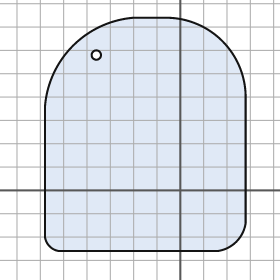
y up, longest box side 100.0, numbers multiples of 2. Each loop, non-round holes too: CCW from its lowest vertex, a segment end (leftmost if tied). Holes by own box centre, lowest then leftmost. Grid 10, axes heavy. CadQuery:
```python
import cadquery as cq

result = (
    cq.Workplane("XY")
    .moveTo(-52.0, -26.0)
    .lineTo(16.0, -26.0)
    .threePointArc((24.0, -22.0), (28.0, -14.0))
    .lineTo(28.0, 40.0)
    .threePointArc((18.0, 64.0), (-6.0, 74.0))
    .lineTo(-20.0, 74.0)
    .threePointArc((-46.0, 62.0), (-58.0, 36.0))
    .lineTo(-58.0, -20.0)
    .threePointArc((-56.0, -24.0), (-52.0, -26.0))
    .close()
    .moveTo(-36.0, 58.0)
    .circle(2.0)
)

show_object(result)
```